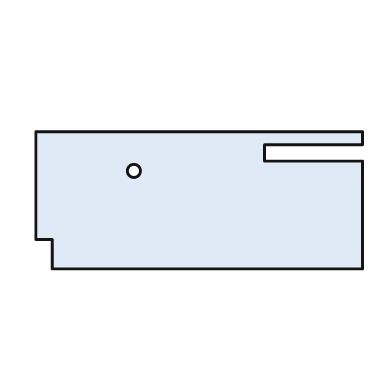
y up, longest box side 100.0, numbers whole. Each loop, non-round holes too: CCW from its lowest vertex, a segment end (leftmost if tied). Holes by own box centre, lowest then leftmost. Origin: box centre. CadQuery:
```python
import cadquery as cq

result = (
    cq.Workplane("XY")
    .moveTo(-45.0, -21.0)
    .lineTo(50.0, -21.0)
    .lineTo(50.0, 12.0)
    .lineTo(20.0, 12.0)
    .lineTo(20.0, 17.0)
    .lineTo(50.0, 17.0)
    .lineTo(50.0, 21.0)
    .lineTo(-50.0, 21.0)
    .lineTo(-50.0, -12.0)
    .lineTo(-45.0, -12.0)
    .close()
    .moveTo(-20.0, 9.0)
    .circle(2.0)
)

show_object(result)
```